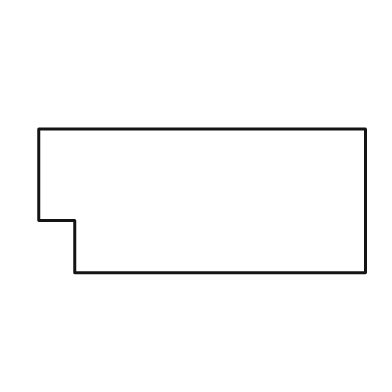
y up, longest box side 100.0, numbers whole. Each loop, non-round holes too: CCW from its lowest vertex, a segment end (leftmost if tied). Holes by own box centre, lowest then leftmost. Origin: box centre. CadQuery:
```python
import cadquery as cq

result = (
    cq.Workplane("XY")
    .moveTo(-39.0, -22.0)
    .lineTo(50.0, -22.0)
    .lineTo(50.0, 22.0)
    .lineTo(-50.0, 22.0)
    .lineTo(-50.0, -6.0)
    .lineTo(-39.0, -6.0)
    .close()
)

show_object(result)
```